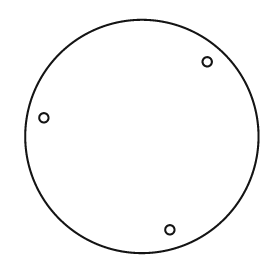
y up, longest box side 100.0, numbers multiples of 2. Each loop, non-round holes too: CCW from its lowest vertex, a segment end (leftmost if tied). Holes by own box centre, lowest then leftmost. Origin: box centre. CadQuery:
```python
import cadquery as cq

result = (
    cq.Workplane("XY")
    .moveTo(0.0, 0.0)
    .circle(50.0)
    .moveTo(12.0, -40.0)
    .circle(2.0)
    .moveTo(-42.0, 8.0)
    .circle(2.0)
    .moveTo(28.0, 32.0)
    .circle(2.0)
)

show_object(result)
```